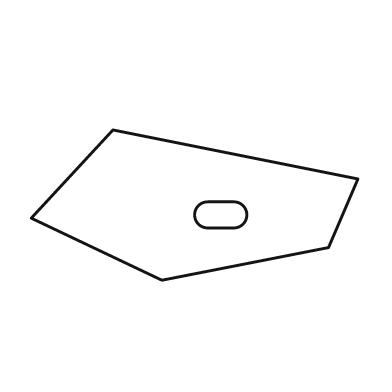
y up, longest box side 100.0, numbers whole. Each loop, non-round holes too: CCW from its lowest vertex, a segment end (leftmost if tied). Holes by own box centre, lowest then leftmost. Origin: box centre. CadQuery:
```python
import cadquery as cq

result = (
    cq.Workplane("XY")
    .moveTo(-10.0, -23.0)
    .lineTo(41.0, -13.0)
    .lineTo(50.0, 8.0)
    .lineTo(-25.0, 23.0)
    .lineTo(-50.0, -4.0)
    .close()
    .moveTo(4.0, -7.0)
    .lineTo(12.0, -7.0)
    .threePointArc((16.0, -3.0), (12.0, 1.0))
    .lineTo(4.0, 1.0)
    .threePointArc((0.0, -3.0), (4.0, -7.0))
    .close()
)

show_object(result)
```